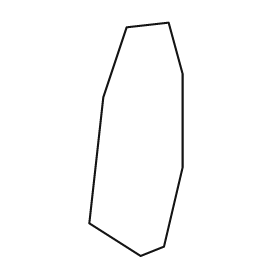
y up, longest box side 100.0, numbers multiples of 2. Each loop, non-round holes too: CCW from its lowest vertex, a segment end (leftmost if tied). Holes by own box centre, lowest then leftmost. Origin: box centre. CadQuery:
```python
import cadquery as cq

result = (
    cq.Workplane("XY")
    .moveTo(2.0, -50.0)
    .lineTo(12.0, -46.0)
    .lineTo(20.0, -12.0)
    .lineTo(20.0, 28.0)
    .lineTo(14.0, 50.0)
    .lineTo(-4.0, 48.0)
    .lineTo(-14.0, 18.0)
    .lineTo(-20.0, -36.0)
    .close()
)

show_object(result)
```